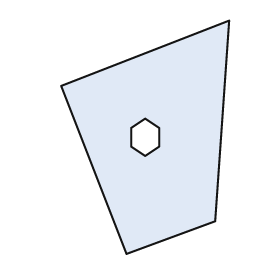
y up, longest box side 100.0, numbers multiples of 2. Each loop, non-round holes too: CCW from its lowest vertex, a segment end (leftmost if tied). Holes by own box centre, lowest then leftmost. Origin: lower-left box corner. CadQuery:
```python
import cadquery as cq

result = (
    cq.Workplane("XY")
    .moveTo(28.0, 0.0)
    .lineTo(66.0, 14.0)
    .lineTo(72.0, 100.0)
    .lineTo(0.0, 72.0)
    .close()
    .moveTo(36.0, 42.0)
    .lineTo(42.0, 46.0)
    .lineTo(42.0, 54.0)
    .lineTo(36.0, 58.0)
    .lineTo(30.0, 54.0)
    .lineTo(30.0, 46.0)
    .close()
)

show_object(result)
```